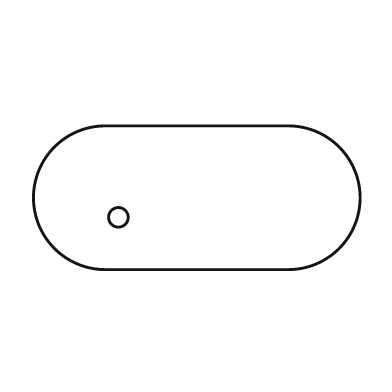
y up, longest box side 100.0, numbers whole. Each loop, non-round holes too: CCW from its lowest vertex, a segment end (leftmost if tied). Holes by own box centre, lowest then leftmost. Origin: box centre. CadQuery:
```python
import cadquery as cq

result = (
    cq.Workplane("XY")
    .moveTo(-28.0, -22.0)
    .lineTo(28.0, -22.0)
    .threePointArc((50.0, 0.0), (28.0, 22.0))
    .lineTo(-28.0, 22.0)
    .threePointArc((-50.0, 0.0), (-28.0, -22.0))
    .close()
    .moveTo(-24.0, -6.0)
    .circle(3.0)
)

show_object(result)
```